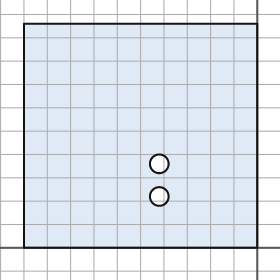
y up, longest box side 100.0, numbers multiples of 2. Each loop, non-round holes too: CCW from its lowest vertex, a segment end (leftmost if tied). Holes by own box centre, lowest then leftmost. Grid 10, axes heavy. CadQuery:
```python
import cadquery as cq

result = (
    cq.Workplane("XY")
    .moveTo(-100.0, 0.0)
    .lineTo(0.0, 0.0)
    .lineTo(0.0, 96.0)
    .lineTo(-100.0, 96.0)
    .close()
    .moveTo(-42.0, 22.0)
    .circle(4.0)
    .moveTo(-42.0, 36.0)
    .circle(4.0)
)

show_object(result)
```